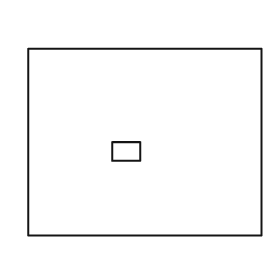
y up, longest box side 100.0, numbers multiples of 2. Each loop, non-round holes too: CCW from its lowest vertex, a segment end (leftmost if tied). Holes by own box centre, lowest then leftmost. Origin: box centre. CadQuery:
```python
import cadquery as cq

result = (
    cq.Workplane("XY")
    .moveTo(-50.0, -40.0)
    .lineTo(50.0, -40.0)
    .lineTo(50.0, 40.0)
    .lineTo(-50.0, 40.0)
    .close()
    .moveTo(-14.0, -8.0)
    .lineTo(-2.0, -8.0)
    .lineTo(-2.0, 0.0)
    .lineTo(-14.0, 0.0)
    .close()
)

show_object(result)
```